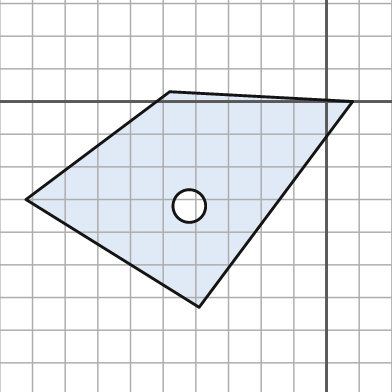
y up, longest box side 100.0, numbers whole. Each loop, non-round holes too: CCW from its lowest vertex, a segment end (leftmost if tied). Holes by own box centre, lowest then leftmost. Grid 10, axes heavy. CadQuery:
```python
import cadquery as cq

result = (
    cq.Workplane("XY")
    .moveTo(-39.0, -63.0)
    .lineTo(8.0, 0.0)
    .lineTo(-48.0, 3.0)
    .lineTo(-92.0, -30.0)
    .close()
    .moveTo(-42.0, -32.0)
    .circle(5.0)
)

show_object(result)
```